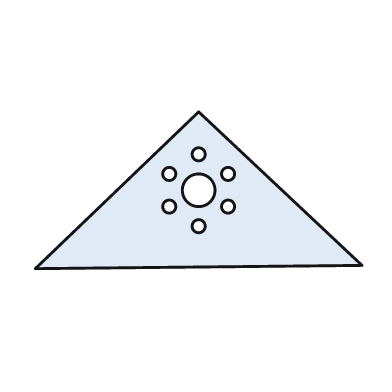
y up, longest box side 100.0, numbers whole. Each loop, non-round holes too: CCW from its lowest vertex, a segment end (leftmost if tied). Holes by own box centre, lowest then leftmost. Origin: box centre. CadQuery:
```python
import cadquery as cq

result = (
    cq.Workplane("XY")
    .moveTo(-50.0, -24.0)
    .lineTo(50.0, -23.0)
    .lineTo(0.0, 24.0)
    .close()
    .moveTo(0.0, -11.0)
    .circle(2.0)
    .moveTo(-9.0, -5.0)
    .circle(2.0)
    .moveTo(9.0, -5.0)
    .circle(2.0)
    .moveTo(0.0, 0.0)
    .circle(5.0)
    .moveTo(-9.0, 5.0)
    .circle(2.0)
    .moveTo(9.0, 5.0)
    .circle(2.0)
    .moveTo(0.0, 11.0)
    .circle(2.0)
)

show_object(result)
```